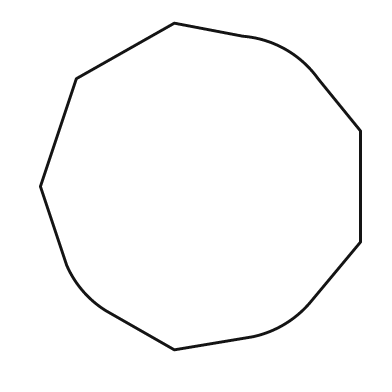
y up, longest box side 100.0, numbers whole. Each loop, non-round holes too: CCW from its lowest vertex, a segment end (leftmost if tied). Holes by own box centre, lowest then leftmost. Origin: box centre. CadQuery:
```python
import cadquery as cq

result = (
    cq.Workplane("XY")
    .moveTo(-8.0, -50.0)
    .lineTo(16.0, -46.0)
    .threePointArc((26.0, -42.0), (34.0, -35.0))
    .lineTo(49.0, -17.0)
    .lineTo(49.0, 17.0)
    .lineTo(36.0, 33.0)
    .threePointArc((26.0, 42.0), (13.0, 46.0))
    .lineTo(-8.0, 50.0)
    .lineTo(-38.0, 33.0)
    .lineTo(-49.0, 0.0)
    .lineTo(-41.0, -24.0)
    .threePointArc((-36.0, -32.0), (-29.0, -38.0))
    .close()
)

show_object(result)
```